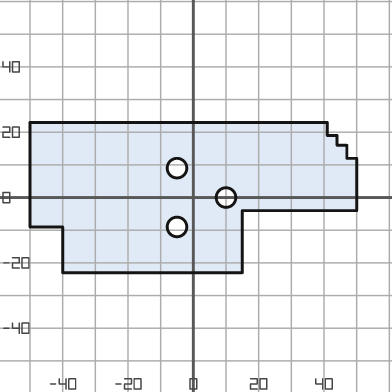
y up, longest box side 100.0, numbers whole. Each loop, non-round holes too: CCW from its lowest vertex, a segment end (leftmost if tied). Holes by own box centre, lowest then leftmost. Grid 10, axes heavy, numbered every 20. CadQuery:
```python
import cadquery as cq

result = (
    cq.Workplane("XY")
    .moveTo(-40.0, -23.0)
    .lineTo(15.0, -23.0)
    .lineTo(15.0, -4.0)
    .lineTo(50.0, -4.0)
    .lineTo(50.0, 12.0)
    .lineTo(47.0, 12.0)
    .lineTo(47.0, 16.0)
    .lineTo(44.0, 16.0)
    .lineTo(44.0, 19.0)
    .lineTo(41.0, 19.0)
    .lineTo(41.0, 23.0)
    .lineTo(-50.0, 23.0)
    .lineTo(-50.0, -9.0)
    .lineTo(-40.0, -9.0)
    .close()
    .moveTo(-5.0, -9.0)
    .circle(3.0)
    .moveTo(10.0, 0.0)
    .circle(3.0)
    .moveTo(-5.0, 9.0)
    .circle(3.0)
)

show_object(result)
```